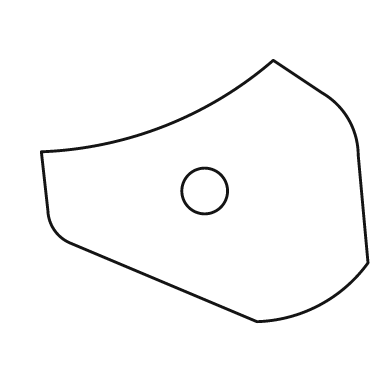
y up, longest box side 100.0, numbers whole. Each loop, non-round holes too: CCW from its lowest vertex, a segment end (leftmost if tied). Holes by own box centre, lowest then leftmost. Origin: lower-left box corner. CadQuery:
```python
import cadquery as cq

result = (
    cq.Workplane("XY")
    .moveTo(66.0, 0.0)
    .threePointArc((85.0, 5.0), (100.0, 18.0))
    .lineTo(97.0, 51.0)
    .threePointArc((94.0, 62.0), (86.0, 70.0))
    .lineTo(71.0, 80.0)
    .threePointArc((38.0, 60.0), (0.0, 52.0))
    .lineTo(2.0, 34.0)
    .threePointArc((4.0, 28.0), (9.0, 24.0))
    .close()
    .moveTo(50.0, 40.0)
    .circle(7.0)
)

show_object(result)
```